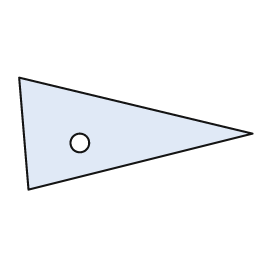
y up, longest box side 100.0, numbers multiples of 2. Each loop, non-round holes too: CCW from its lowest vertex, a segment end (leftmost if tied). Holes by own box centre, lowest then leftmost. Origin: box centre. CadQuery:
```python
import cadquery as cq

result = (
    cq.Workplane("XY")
    .moveTo(-46.0, -24.0)
    .lineTo(50.0, 0.0)
    .lineTo(-50.0, 24.0)
    .close()
    .moveTo(-24.0, -4.0)
    .circle(4.0)
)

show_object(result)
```